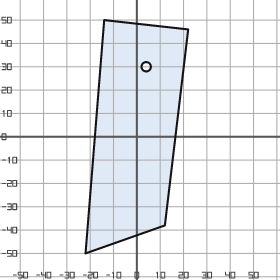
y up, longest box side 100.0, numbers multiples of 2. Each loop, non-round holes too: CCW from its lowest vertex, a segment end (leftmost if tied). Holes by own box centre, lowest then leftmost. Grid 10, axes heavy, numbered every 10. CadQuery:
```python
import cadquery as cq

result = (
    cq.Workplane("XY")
    .moveTo(-22.0, -50.0)
    .lineTo(12.0, -38.0)
    .lineTo(22.0, 46.0)
    .lineTo(-14.0, 50.0)
    .close()
    .moveTo(4.0, 30.0)
    .circle(2.0)
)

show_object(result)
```